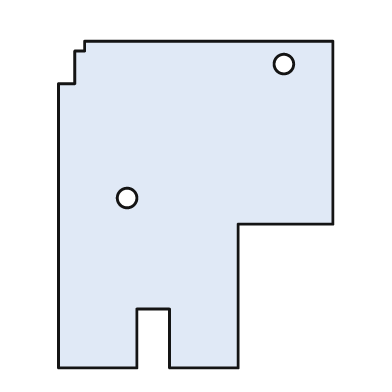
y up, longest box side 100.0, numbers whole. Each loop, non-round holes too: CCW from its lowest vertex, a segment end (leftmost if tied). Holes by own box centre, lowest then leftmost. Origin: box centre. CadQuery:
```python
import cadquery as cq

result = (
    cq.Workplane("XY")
    .moveTo(-42.0, -50.0)
    .lineTo(-18.0, -50.0)
    .lineTo(-18.0, -32.0)
    .lineTo(-8.0, -32.0)
    .lineTo(-8.0, -50.0)
    .lineTo(13.0, -50.0)
    .lineTo(13.0, -6.0)
    .lineTo(42.0, -6.0)
    .lineTo(42.0, 50.0)
    .lineTo(-34.0, 50.0)
    .lineTo(-34.0, 47.0)
    .lineTo(-37.0, 47.0)
    .lineTo(-37.0, 37.0)
    .lineTo(-42.0, 37.0)
    .close()
    .moveTo(-21.0, 2.0)
    .circle(3.0)
    .moveTo(27.0, 43.0)
    .circle(3.0)
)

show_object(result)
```